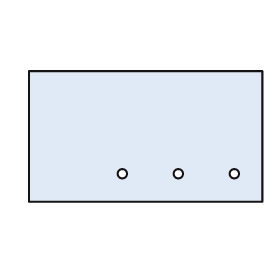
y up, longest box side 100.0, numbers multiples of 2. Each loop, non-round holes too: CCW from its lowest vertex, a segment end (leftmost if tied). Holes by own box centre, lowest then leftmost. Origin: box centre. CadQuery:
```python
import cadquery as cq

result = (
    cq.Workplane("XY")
    .moveTo(-50.0, -28.0)
    .lineTo(50.0, -28.0)
    .lineTo(50.0, 28.0)
    .lineTo(-50.0, 28.0)
    .close()
    .moveTo(-10.0, -16.0)
    .circle(2.0)
    .moveTo(14.0, -16.0)
    .circle(2.0)
    .moveTo(38.0, -16.0)
    .circle(2.0)
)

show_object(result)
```